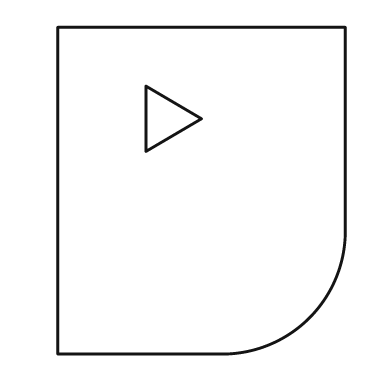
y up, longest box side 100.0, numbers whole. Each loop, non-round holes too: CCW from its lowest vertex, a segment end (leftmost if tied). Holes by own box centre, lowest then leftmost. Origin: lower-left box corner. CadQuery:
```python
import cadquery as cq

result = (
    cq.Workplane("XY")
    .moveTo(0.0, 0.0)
    .lineTo(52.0, 0.0)
    .threePointArc((77.0, 11.0), (88.0, 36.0))
    .lineTo(88.0, 100.0)
    .lineTo(0.0, 100.0)
    .close()
    .moveTo(27.0, 62.0)
    .lineTo(44.0, 72.0)
    .lineTo(27.0, 82.0)
    .close()
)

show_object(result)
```